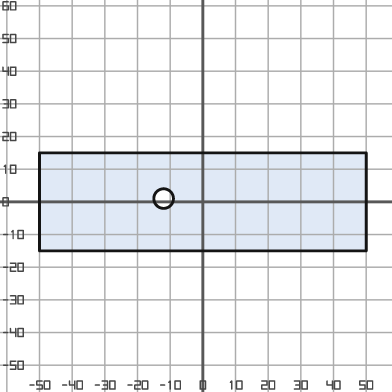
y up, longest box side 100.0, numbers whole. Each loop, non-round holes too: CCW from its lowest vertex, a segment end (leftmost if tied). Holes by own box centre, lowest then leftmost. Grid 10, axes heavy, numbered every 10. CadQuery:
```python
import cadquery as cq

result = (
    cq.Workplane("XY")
    .moveTo(-50.0, -15.0)
    .lineTo(50.0, -15.0)
    .lineTo(50.0, 15.0)
    .lineTo(-50.0, 15.0)
    .close()
    .moveTo(-12.0, 1.0)
    .circle(3.0)
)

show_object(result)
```